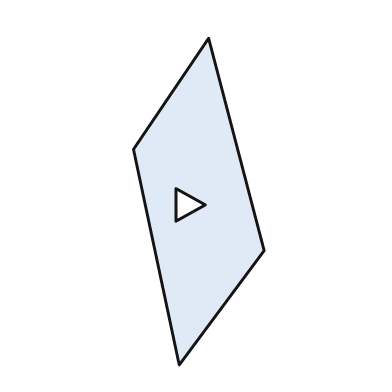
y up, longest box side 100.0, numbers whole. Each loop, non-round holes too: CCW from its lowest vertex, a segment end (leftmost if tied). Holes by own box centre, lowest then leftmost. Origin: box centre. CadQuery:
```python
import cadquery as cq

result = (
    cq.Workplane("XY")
    .moveTo(-6.0, -50.0)
    .lineTo(20.0, -15.0)
    .lineTo(3.0, 50.0)
    .lineTo(-20.0, 16.0)
    .close()
    .moveTo(-7.0, -6.0)
    .lineTo(2.0, -1.0)
    .lineTo(-7.0, 4.0)
    .close()
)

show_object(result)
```